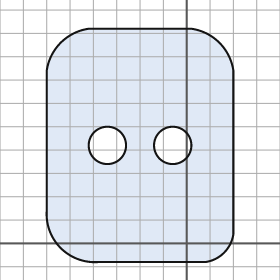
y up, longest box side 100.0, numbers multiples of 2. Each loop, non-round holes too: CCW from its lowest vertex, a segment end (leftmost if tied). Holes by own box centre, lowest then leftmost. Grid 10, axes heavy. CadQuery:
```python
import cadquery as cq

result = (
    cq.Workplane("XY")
    .moveTo(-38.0, -8.0)
    .lineTo(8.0, -8.0)
    .threePointArc((16.0, -4.0), (20.0, 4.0))
    .lineTo(20.0, 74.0)
    .threePointArc((14.0, 86.0), (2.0, 92.0))
    .lineTo(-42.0, 92.0)
    .threePointArc((-54.0, 86.0), (-60.0, 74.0))
    .lineTo(-60.0, 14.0)
    .threePointArc((-54.0, -2.0), (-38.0, -8.0))
    .close()
    .moveTo(-34.0, 42.0)
    .circle(8.0)
    .moveTo(-6.0, 42.0)
    .circle(8.0)
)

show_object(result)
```